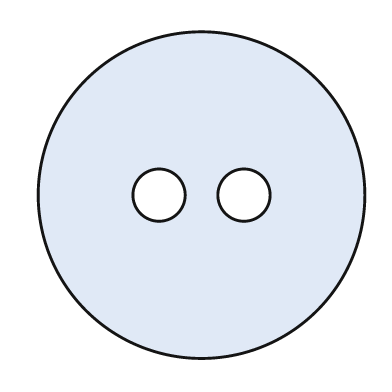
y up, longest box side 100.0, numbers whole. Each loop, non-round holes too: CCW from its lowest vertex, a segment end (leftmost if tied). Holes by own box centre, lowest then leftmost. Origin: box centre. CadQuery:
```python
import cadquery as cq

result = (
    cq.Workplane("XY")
    .moveTo(0.0, 0.0)
    .circle(50.0)
    .moveTo(-13.0, 0.0)
    .circle(8.0)
    .moveTo(13.0, 0.0)
    .circle(8.0)
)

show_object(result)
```